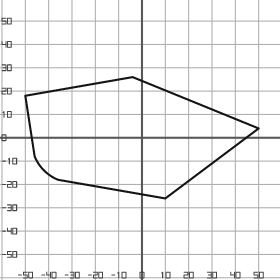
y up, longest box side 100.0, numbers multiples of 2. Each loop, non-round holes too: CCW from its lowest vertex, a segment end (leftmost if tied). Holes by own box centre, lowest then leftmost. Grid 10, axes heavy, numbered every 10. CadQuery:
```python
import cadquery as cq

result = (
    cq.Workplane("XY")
    .moveTo(10.0, -26.0)
    .lineTo(50.0, 4.0)
    .lineTo(-4.0, 26.0)
    .lineTo(-50.0, 18.0)
    .lineTo(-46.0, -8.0)
    .threePointArc((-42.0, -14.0), (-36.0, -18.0))
    .close()
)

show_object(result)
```